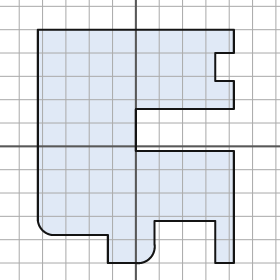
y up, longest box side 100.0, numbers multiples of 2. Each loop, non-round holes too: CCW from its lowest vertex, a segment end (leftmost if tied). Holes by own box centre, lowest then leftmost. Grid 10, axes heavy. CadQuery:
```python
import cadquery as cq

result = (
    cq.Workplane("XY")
    .moveTo(-12.0, -50.0)
    .lineTo(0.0, -50.0)
    .threePointArc((6.0, -48.0), (8.0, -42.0))
    .lineTo(8.0, -32.0)
    .lineTo(34.0, -32.0)
    .lineTo(34.0, -50.0)
    .lineTo(42.0, -50.0)
    .lineTo(42.0, -2.0)
    .lineTo(0.0, -2.0)
    .lineTo(0.0, 16.0)
    .lineTo(42.0, 16.0)
    .lineTo(42.0, 28.0)
    .lineTo(34.0, 28.0)
    .lineTo(34.0, 40.0)
    .lineTo(42.0, 40.0)
    .lineTo(42.0, 50.0)
    .lineTo(-42.0, 50.0)
    .lineTo(-42.0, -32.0)
    .threePointArc((-40.0, -36.0), (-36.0, -38.0))
    .lineTo(-12.0, -38.0)
    .close()
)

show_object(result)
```